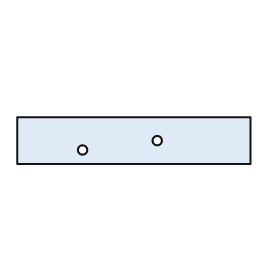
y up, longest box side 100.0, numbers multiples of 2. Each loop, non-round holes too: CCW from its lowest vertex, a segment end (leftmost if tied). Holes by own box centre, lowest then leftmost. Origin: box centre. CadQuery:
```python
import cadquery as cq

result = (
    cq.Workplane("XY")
    .moveTo(-50.0, -10.0)
    .lineTo(50.0, -10.0)
    .lineTo(50.0, 10.0)
    .lineTo(-50.0, 10.0)
    .close()
    .moveTo(-22.0, -4.0)
    .circle(2.0)
    .moveTo(10.0, 0.0)
    .circle(2.0)
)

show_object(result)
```